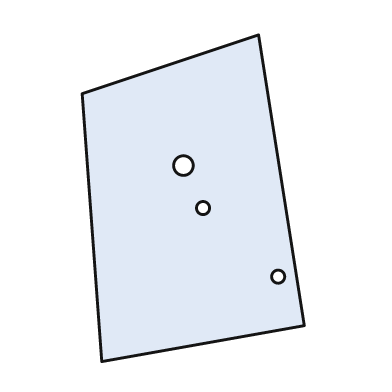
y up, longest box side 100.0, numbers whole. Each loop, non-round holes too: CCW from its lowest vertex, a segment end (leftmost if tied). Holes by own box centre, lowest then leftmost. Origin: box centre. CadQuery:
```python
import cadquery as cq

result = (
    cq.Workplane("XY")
    .moveTo(-28.0, -50.0)
    .lineTo(34.0, -39.0)
    .lineTo(20.0, 50.0)
    .lineTo(-34.0, 32.0)
    .close()
    .moveTo(26.0, -24.0)
    .circle(2.0)
    .moveTo(3.0, -3.0)
    .circle(2.0)
    .moveTo(-3.0, 10.0)
    .circle(3.0)
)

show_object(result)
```